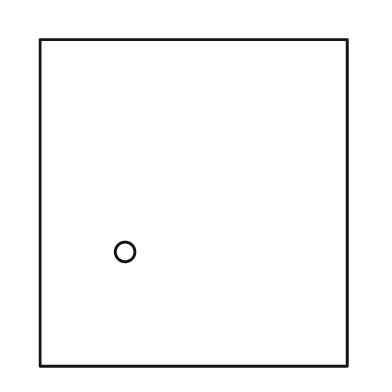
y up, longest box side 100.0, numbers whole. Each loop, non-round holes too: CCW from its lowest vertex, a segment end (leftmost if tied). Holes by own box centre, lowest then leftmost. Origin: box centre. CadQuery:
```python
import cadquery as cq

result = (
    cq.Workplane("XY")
    .moveTo(-47.0, -50.0)
    .lineTo(47.0, -50.0)
    .lineTo(47.0, 50.0)
    .lineTo(-47.0, 50.0)
    .close()
    .moveTo(-21.0, -15.0)
    .circle(3.0)
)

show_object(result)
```